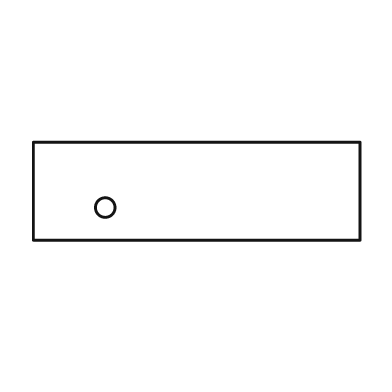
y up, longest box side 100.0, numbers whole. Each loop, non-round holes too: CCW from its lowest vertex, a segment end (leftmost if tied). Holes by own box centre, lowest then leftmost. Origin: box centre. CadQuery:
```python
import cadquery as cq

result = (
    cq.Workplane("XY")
    .moveTo(-50.0, -15.0)
    .lineTo(50.0, -15.0)
    .lineTo(50.0, 15.0)
    .lineTo(-50.0, 15.0)
    .close()
    .moveTo(-28.0, -5.0)
    .circle(3.0)
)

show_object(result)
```